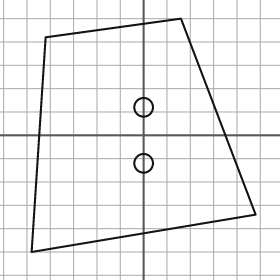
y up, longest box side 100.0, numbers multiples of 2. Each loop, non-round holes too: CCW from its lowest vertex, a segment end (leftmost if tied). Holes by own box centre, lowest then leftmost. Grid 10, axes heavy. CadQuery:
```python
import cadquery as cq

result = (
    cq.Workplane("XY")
    .moveTo(-48.0, -50.0)
    .lineTo(48.0, -34.0)
    .lineTo(16.0, 50.0)
    .lineTo(-42.0, 42.0)
    .close()
    .moveTo(0.0, -12.0)
    .circle(4.0)
    .moveTo(0.0, 12.0)
    .circle(4.0)
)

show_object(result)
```